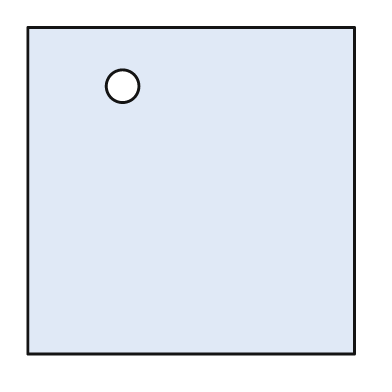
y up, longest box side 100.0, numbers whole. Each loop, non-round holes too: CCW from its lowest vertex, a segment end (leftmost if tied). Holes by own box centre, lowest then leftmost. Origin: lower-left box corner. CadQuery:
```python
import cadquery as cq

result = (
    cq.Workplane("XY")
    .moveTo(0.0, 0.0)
    .lineTo(100.0, 0.0)
    .lineTo(100.0, 100.0)
    .lineTo(0.0, 100.0)
    .close()
    .moveTo(29.0, 82.0)
    .circle(5.0)
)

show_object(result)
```